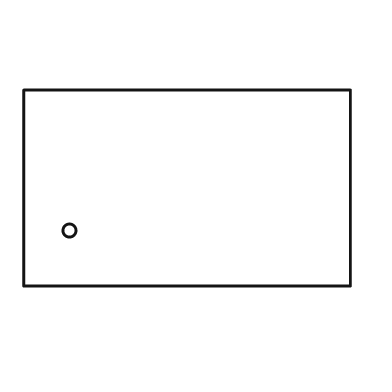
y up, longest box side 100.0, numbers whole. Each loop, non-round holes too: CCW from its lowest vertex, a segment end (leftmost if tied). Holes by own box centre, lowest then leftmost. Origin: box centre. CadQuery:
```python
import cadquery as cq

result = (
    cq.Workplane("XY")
    .moveTo(-50.0, -30.0)
    .lineTo(50.0, -30.0)
    .lineTo(50.0, 30.0)
    .lineTo(-50.0, 30.0)
    .close()
    .moveTo(-36.0, -13.0)
    .circle(2.0)
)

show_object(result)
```